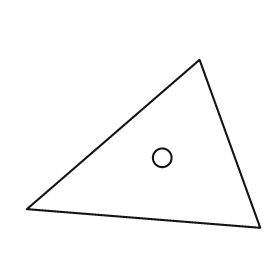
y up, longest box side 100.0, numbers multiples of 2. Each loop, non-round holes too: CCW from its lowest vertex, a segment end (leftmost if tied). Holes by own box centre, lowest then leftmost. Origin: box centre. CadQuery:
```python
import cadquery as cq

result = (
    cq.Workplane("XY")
    .moveTo(50.0, -36.0)
    .lineTo(24.0, 36.0)
    .lineTo(-50.0, -28.0)
    .close()
    .moveTo(8.0, -6.0)
    .circle(4.0)
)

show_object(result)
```